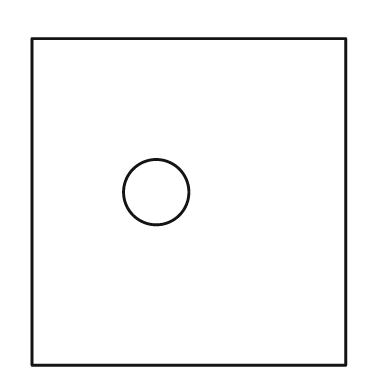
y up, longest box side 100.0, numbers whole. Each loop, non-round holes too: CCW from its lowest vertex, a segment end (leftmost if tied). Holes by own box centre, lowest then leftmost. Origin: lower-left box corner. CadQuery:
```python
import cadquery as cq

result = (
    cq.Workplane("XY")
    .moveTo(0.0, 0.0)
    .lineTo(96.0, 0.0)
    .lineTo(96.0, 100.0)
    .lineTo(0.0, 100.0)
    .close()
    .moveTo(38.0, 53.0)
    .circle(10.0)
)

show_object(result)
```